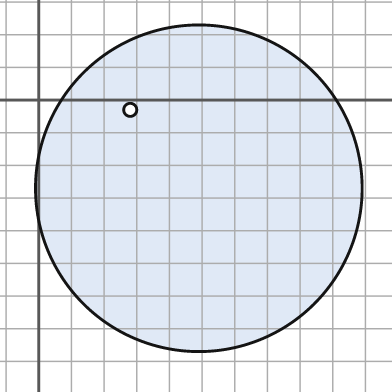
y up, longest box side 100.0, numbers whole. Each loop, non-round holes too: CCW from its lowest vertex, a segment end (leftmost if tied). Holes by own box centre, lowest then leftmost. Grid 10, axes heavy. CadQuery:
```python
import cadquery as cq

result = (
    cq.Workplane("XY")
    .moveTo(49.0, -27.0)
    .circle(50.0)
    .moveTo(28.0, -3.0)
    .circle(2.0)
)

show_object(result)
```